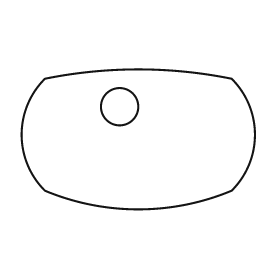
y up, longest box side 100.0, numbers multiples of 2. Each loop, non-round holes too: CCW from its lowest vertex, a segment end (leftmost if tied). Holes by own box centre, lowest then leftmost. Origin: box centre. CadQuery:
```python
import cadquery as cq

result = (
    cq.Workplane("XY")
    .moveTo(-40.0, -22.0)
    .threePointArc((0.0, -30.0), (40.0, -22.0))
    .threePointArc((50.0, 2.0), (40.0, 26.0))
    .threePointArc((0.0, 30.0), (-40.0, 26.0))
    .threePointArc((-50.0, 2.0), (-40.0, -22.0))
    .close()
    .moveTo(-8.0, 14.0)
    .circle(8.0)
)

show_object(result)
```